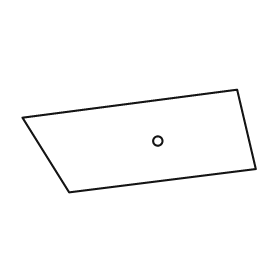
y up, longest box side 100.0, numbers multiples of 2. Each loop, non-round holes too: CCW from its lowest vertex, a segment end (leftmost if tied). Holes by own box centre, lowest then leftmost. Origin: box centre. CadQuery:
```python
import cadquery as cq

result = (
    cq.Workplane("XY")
    .moveTo(-30.0, -22.0)
    .lineTo(50.0, -12.0)
    .lineTo(42.0, 22.0)
    .lineTo(-50.0, 10.0)
    .close()
    .moveTo(8.0, 0.0)
    .circle(2.0)
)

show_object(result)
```